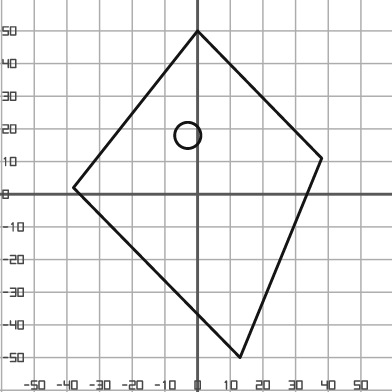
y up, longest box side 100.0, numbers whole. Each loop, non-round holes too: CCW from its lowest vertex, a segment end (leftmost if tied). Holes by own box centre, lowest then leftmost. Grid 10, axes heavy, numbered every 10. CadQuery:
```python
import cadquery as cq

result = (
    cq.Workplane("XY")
    .moveTo(13.0, -50.0)
    .lineTo(38.0, 11.0)
    .lineTo(0.0, 50.0)
    .lineTo(-38.0, 2.0)
    .close()
    .moveTo(-3.0, 18.0)
    .circle(4.0)
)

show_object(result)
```